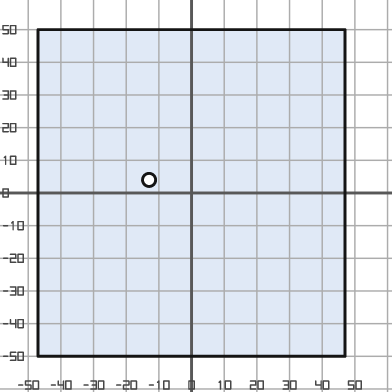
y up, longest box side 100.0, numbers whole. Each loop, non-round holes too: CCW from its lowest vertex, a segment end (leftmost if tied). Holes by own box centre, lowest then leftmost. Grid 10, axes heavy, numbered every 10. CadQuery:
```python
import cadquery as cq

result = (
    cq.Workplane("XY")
    .moveTo(-47.0, -50.0)
    .lineTo(47.0, -50.0)
    .lineTo(47.0, 50.0)
    .lineTo(-47.0, 50.0)
    .close()
    .moveTo(-13.0, 4.0)
    .circle(2.0)
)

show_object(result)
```